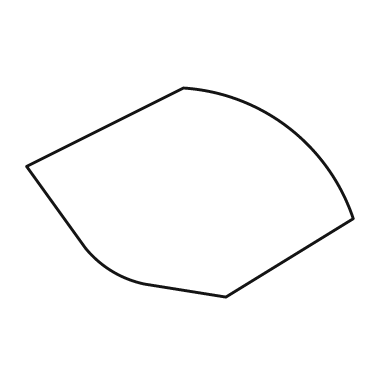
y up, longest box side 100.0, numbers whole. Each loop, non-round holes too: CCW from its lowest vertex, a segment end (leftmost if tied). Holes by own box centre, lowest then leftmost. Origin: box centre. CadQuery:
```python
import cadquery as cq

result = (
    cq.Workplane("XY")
    .moveTo(11.0, -32.0)
    .lineTo(50.0, -8.0)
    .threePointArc((30.0, 20.0), (-2.0, 32.0))
    .lineTo(-50.0, 8.0)
    .lineTo(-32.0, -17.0)
    .threePointArc((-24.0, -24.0), (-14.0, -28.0))
    .close()
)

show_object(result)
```